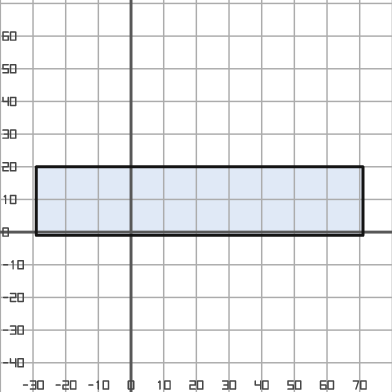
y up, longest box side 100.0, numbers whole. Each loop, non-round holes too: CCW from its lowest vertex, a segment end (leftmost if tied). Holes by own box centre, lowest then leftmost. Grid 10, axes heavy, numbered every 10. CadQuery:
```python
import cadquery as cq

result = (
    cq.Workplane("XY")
    .moveTo(-29.0, -1.0)
    .lineTo(71.0, -1.0)
    .lineTo(71.0, 20.0)
    .lineTo(-29.0, 20.0)
    .close()
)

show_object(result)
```